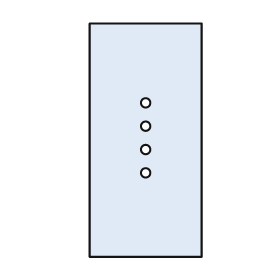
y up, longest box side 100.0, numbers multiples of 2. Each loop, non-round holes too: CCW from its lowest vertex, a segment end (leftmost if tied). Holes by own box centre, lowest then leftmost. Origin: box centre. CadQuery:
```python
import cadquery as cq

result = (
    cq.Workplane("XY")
    .moveTo(-24.0, -50.0)
    .lineTo(24.0, -50.0)
    .lineTo(24.0, 50.0)
    .lineTo(-24.0, 50.0)
    .close()
    .moveTo(0.0, -14.0)
    .circle(2.0)
    .moveTo(0.0, -4.0)
    .circle(2.0)
    .moveTo(0.0, 6.0)
    .circle(2.0)
    .moveTo(0.0, 16.0)
    .circle(2.0)
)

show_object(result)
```